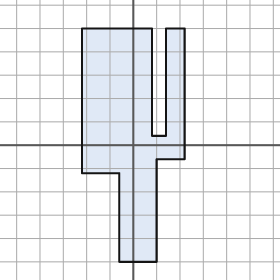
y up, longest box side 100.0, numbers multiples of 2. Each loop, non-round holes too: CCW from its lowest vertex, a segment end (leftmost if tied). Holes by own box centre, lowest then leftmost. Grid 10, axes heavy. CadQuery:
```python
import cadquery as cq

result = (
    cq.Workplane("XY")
    .moveTo(-6.0, -50.0)
    .lineTo(10.0, -50.0)
    .lineTo(10.0, -6.0)
    .lineTo(22.0, -6.0)
    .lineTo(22.0, 50.0)
    .lineTo(14.0, 50.0)
    .lineTo(14.0, 4.0)
    .lineTo(8.0, 4.0)
    .lineTo(8.0, 50.0)
    .lineTo(-22.0, 50.0)
    .lineTo(-22.0, -12.0)
    .lineTo(-6.0, -12.0)
    .close()
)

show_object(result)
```